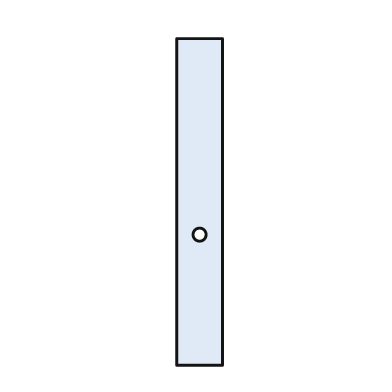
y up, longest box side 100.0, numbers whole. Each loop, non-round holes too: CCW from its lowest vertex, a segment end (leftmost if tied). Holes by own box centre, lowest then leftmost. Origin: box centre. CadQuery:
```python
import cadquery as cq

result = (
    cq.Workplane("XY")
    .moveTo(-7.0, -50.0)
    .lineTo(7.0, -50.0)
    .lineTo(7.0, 50.0)
    .lineTo(-7.0, 50.0)
    .close()
    .moveTo(0.0, -10.0)
    .circle(2.0)
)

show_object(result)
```